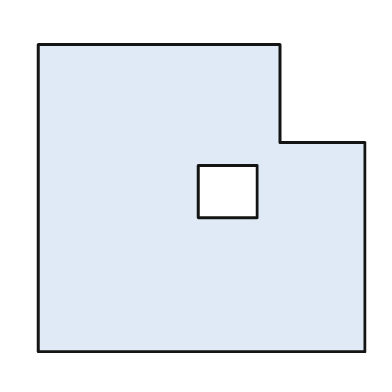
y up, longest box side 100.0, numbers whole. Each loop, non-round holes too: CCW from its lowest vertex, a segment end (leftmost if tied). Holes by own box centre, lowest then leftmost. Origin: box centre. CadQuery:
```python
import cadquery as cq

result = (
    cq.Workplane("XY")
    .moveTo(-50.0, -47.0)
    .lineTo(50.0, -47.0)
    .lineTo(50.0, 17.0)
    .lineTo(24.0, 17.0)
    .lineTo(24.0, 47.0)
    .lineTo(-50.0, 47.0)
    .close()
    .moveTo(-1.0, -6.0)
    .lineTo(17.0, -6.0)
    .lineTo(17.0, 10.0)
    .lineTo(-1.0, 10.0)
    .close()
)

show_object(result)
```